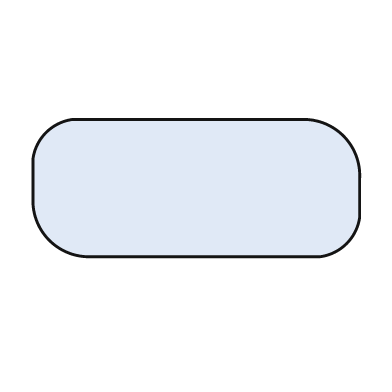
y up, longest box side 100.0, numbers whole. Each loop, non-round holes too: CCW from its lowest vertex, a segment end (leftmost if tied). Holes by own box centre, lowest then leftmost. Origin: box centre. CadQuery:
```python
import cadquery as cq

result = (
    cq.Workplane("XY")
    .moveTo(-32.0, -21.0)
    .lineTo(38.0, -21.0)
    .threePointArc((46.0, -17.0), (50.0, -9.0))
    .lineTo(50.0, 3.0)
    .threePointArc((45.0, 16.0), (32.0, 21.0))
    .lineTo(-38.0, 21.0)
    .threePointArc((-46.0, 17.0), (-50.0, 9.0))
    .lineTo(-50.0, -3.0)
    .threePointArc((-45.0, -16.0), (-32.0, -21.0))
    .close()
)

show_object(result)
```